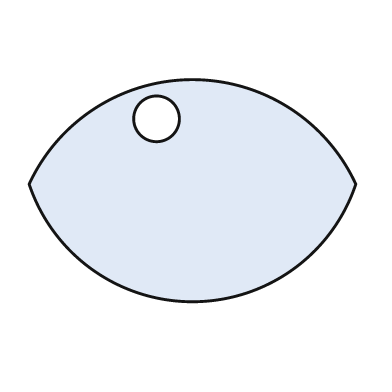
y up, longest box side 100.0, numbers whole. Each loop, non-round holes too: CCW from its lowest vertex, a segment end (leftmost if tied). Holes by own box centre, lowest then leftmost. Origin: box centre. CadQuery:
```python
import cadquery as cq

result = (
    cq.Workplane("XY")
    .moveTo(-50.0, 2.0)
    .threePointArc((0.0, -34.0), (50.0, 2.0))
    .threePointArc((0.0, 34.0), (-50.0, 2.0))
    .close()
    .moveTo(-11.0, 22.0)
    .circle(7.0)
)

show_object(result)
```